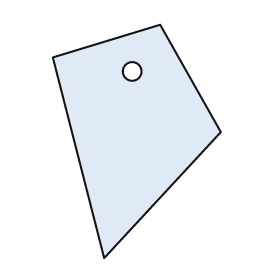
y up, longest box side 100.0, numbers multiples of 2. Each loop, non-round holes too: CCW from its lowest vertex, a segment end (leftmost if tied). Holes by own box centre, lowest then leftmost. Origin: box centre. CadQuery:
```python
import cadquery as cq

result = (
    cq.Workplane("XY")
    .moveTo(-14.0, -50.0)
    .lineTo(36.0, 4.0)
    .lineTo(10.0, 50.0)
    .lineTo(-36.0, 36.0)
    .close()
    .moveTo(-2.0, 30.0)
    .circle(4.0)
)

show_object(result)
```